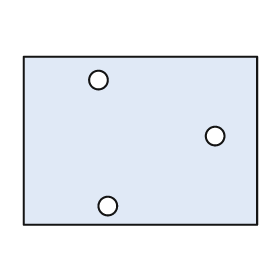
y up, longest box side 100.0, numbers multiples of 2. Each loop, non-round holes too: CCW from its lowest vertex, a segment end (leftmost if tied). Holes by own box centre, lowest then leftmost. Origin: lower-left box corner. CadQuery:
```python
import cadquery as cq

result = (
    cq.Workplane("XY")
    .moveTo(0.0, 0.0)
    .lineTo(100.0, 0.0)
    .lineTo(100.0, 72.0)
    .lineTo(0.0, 72.0)
    .close()
    .moveTo(36.0, 8.0)
    .circle(4.0)
    .moveTo(82.0, 38.0)
    .circle(4.0)
    .moveTo(32.0, 62.0)
    .circle(4.0)
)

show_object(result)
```